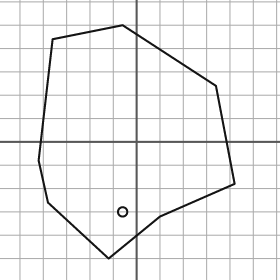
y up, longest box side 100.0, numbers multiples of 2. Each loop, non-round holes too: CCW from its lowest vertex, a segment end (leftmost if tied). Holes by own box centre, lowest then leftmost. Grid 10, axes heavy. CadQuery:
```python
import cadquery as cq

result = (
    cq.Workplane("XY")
    .moveTo(-12.0, -50.0)
    .lineTo(10.0, -32.0)
    .lineTo(42.0, -18.0)
    .lineTo(34.0, 24.0)
    .lineTo(-6.0, 50.0)
    .lineTo(-36.0, 44.0)
    .lineTo(-42.0, -8.0)
    .lineTo(-38.0, -26.0)
    .close()
    .moveTo(-6.0, -30.0)
    .circle(2.0)
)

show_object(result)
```